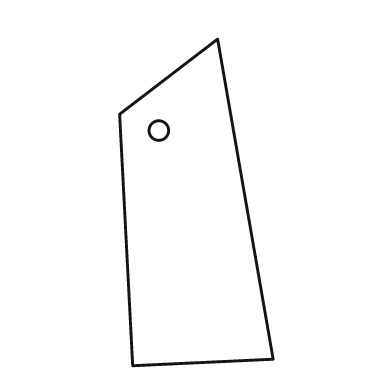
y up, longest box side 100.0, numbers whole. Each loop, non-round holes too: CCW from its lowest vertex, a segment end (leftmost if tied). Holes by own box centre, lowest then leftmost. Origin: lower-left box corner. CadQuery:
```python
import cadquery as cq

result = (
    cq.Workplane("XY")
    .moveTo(4.0, 0.0)
    .lineTo(47.0, 2.0)
    .lineTo(30.0, 100.0)
    .lineTo(0.0, 77.0)
    .close()
    .moveTo(12.0, 72.0)
    .circle(3.0)
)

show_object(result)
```